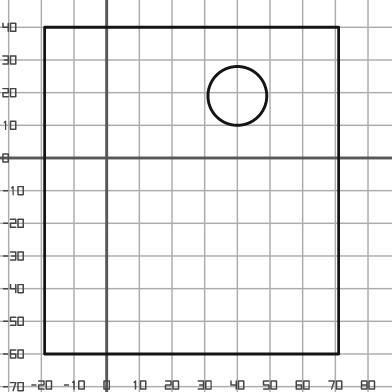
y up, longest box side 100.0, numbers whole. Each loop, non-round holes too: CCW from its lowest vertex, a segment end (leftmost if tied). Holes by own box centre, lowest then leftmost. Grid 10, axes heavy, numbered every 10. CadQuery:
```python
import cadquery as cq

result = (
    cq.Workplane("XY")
    .moveTo(-19.0, -60.0)
    .lineTo(71.0, -60.0)
    .lineTo(71.0, 40.0)
    .lineTo(-19.0, 40.0)
    .close()
    .moveTo(40.0, 19.0)
    .circle(9.0)
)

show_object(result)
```